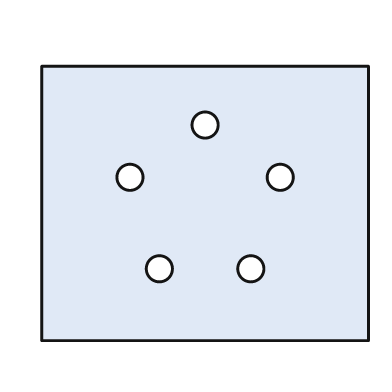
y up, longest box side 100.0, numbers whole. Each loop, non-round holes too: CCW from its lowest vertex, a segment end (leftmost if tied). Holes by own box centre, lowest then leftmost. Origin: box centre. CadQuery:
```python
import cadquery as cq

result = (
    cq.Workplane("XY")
    .moveTo(-50.0, -42.0)
    .lineTo(50.0, -42.0)
    .lineTo(50.0, 42.0)
    .lineTo(-50.0, 42.0)
    .close()
    .moveTo(-14.0, -20.0)
    .circle(4.0)
    .moveTo(14.0, -20.0)
    .circle(4.0)
    .moveTo(-23.0, 8.0)
    .circle(4.0)
    .moveTo(23.0, 8.0)
    .circle(4.0)
    .moveTo(0.0, 24.0)
    .circle(4.0)
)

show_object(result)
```